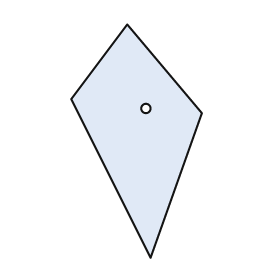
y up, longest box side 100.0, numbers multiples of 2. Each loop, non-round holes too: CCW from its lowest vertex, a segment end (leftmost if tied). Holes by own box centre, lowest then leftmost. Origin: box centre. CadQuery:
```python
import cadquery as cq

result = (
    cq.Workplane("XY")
    .moveTo(6.0, -50.0)
    .lineTo(28.0, 12.0)
    .lineTo(-4.0, 50.0)
    .lineTo(-28.0, 18.0)
    .close()
    .moveTo(4.0, 14.0)
    .circle(2.0)
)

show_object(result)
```